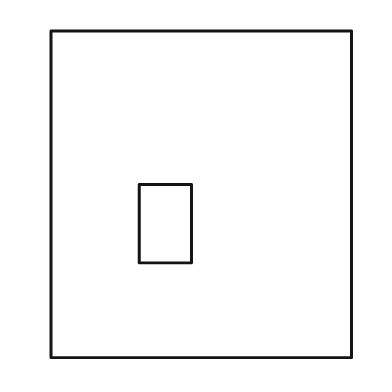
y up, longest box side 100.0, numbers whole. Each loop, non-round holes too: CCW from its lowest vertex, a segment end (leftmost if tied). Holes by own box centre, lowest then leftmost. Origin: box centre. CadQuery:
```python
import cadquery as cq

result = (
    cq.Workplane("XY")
    .moveTo(-46.0, -50.0)
    .lineTo(46.0, -50.0)
    .lineTo(46.0, 50.0)
    .lineTo(-46.0, 50.0)
    .close()
    .moveTo(-19.0, -21.0)
    .lineTo(-3.0, -21.0)
    .lineTo(-3.0, 3.0)
    .lineTo(-19.0, 3.0)
    .close()
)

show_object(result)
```